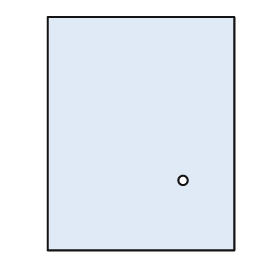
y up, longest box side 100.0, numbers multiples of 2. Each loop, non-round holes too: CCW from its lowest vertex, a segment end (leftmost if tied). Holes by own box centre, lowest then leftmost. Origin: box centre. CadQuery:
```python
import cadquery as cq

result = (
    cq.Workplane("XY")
    .moveTo(-40.0, -50.0)
    .lineTo(40.0, -50.0)
    .lineTo(40.0, 50.0)
    .lineTo(-40.0, 50.0)
    .close()
    .moveTo(18.0, -20.0)
    .circle(2.0)
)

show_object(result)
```